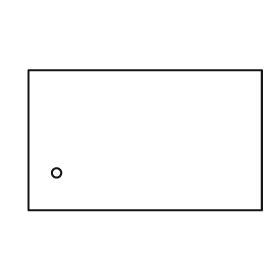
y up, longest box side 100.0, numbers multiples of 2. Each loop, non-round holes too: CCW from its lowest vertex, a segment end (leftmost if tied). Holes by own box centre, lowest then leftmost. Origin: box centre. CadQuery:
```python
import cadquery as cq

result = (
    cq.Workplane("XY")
    .moveTo(-50.0, -30.0)
    .lineTo(50.0, -30.0)
    .lineTo(50.0, 30.0)
    .lineTo(-50.0, 30.0)
    .close()
    .moveTo(-38.0, -14.0)
    .circle(2.0)
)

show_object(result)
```